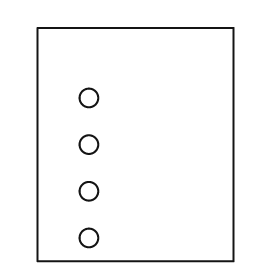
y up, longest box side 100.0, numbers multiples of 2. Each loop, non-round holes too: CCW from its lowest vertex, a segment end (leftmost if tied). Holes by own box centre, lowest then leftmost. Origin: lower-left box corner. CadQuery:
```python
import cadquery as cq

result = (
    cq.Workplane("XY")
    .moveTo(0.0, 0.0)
    .lineTo(84.0, 0.0)
    .lineTo(84.0, 100.0)
    .lineTo(0.0, 100.0)
    .close()
    .moveTo(22.0, 10.0)
    .circle(4.0)
    .moveTo(22.0, 30.0)
    .circle(4.0)
    .moveTo(22.0, 50.0)
    .circle(4.0)
    .moveTo(22.0, 70.0)
    .circle(4.0)
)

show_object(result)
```